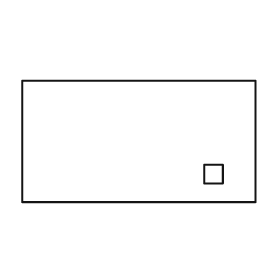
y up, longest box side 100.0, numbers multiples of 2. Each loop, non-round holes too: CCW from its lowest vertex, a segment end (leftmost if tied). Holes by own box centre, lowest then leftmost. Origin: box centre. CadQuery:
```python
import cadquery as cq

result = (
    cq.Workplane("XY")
    .moveTo(-50.0, -26.0)
    .lineTo(50.0, -26.0)
    .lineTo(50.0, 26.0)
    .lineTo(-50.0, 26.0)
    .close()
    .moveTo(28.0, -18.0)
    .lineTo(36.0, -18.0)
    .lineTo(36.0, -10.0)
    .lineTo(28.0, -10.0)
    .close()
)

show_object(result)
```